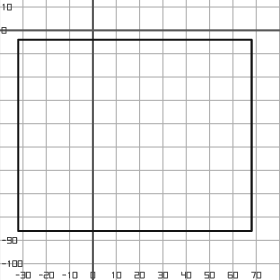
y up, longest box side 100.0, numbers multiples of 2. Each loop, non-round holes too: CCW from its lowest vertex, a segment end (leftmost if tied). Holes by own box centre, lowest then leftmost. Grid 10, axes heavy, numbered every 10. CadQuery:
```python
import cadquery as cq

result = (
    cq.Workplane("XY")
    .moveTo(-32.0, -86.0)
    .lineTo(68.0, -86.0)
    .lineTo(68.0, -4.0)
    .lineTo(-32.0, -4.0)
    .close()
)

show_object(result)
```